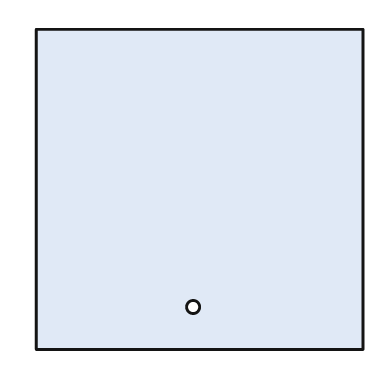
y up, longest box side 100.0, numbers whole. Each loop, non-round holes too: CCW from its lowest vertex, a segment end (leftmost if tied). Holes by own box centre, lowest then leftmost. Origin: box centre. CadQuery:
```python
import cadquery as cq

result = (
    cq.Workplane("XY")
    .moveTo(-50.0, -49.0)
    .lineTo(50.0, -49.0)
    .lineTo(50.0, 49.0)
    .lineTo(-50.0, 49.0)
    .close()
    .moveTo(-2.0, -36.0)
    .circle(2.0)
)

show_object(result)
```